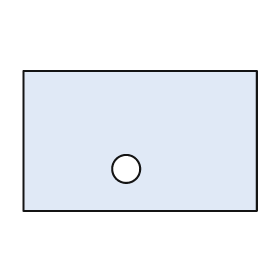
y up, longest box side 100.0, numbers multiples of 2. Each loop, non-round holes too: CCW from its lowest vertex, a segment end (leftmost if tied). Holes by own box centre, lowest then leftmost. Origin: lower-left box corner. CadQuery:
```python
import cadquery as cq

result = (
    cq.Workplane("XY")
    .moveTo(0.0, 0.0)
    .lineTo(100.0, 0.0)
    .lineTo(100.0, 60.0)
    .lineTo(0.0, 60.0)
    .close()
    .moveTo(44.0, 18.0)
    .circle(6.0)
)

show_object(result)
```